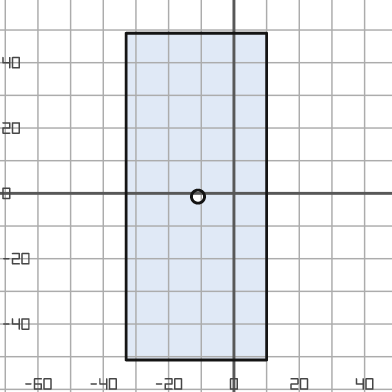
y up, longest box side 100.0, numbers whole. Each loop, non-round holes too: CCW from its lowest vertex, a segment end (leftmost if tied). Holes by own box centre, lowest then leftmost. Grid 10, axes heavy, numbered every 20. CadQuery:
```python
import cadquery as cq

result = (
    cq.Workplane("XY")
    .moveTo(-33.0, -51.0)
    .lineTo(10.0, -51.0)
    .lineTo(10.0, 49.0)
    .lineTo(-33.0, 49.0)
    .close()
    .moveTo(-11.0, -1.0)
    .circle(2.0)
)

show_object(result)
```